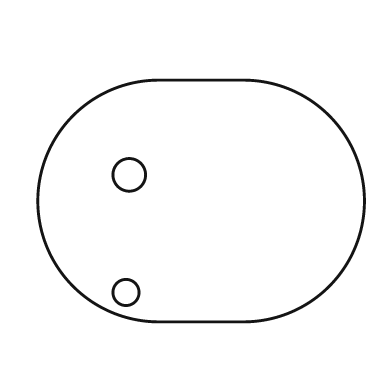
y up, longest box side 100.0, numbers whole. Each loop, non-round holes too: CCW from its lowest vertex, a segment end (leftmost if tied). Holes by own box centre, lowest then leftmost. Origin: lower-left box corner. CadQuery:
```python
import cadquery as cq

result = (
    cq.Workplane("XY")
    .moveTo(37.0, 0.0)
    .lineTo(63.0, 0.0)
    .threePointArc((100.0, 37.0), (63.0, 74.0))
    .lineTo(37.0, 74.0)
    .threePointArc((0.0, 37.0), (37.0, 0.0))
    .close()
    .moveTo(27.0, 9.0)
    .circle(4.0)
    .moveTo(28.0, 45.0)
    .circle(5.0)
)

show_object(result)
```